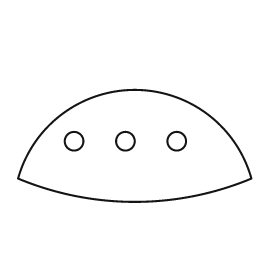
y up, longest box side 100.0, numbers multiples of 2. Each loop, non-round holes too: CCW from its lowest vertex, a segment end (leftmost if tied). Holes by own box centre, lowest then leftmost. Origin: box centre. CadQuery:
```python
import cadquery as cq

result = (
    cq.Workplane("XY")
    .moveTo(-50.0, -14.0)
    .threePointArc((0.0, -24.0), (50.0, -14.0))
    .threePointArc((0.0, 24.0), (-50.0, -14.0))
    .close()
    .moveTo(-26.0, 2.0)
    .circle(4.0)
    .moveTo(-4.0, 2.0)
    .circle(4.0)
    .moveTo(18.0, 2.0)
    .circle(4.0)
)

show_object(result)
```